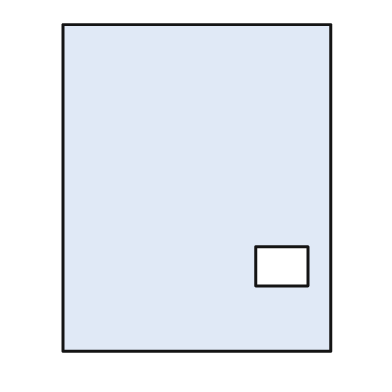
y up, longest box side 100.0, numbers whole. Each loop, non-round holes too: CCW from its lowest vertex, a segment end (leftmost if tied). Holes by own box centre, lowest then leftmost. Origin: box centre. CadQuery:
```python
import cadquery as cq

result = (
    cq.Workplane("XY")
    .moveTo(-41.0, -50.0)
    .lineTo(41.0, -50.0)
    .lineTo(41.0, 50.0)
    .lineTo(-41.0, 50.0)
    .close()
    .moveTo(18.0, -30.0)
    .lineTo(34.0, -30.0)
    .lineTo(34.0, -18.0)
    .lineTo(18.0, -18.0)
    .close()
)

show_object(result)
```